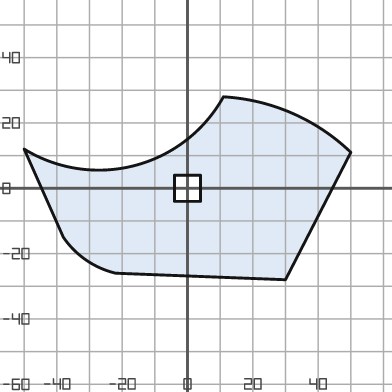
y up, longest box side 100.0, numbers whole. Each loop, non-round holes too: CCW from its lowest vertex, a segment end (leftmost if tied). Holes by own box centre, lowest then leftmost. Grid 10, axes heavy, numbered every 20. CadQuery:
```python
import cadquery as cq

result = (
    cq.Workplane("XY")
    .moveTo(30.0, -28.0)
    .lineTo(50.0, 11.0)
    .threePointArc((32.0, 23.0), (11.0, 28.0))
    .threePointArc((-16.0, 7.0), (-50.0, 12.0))
    .lineTo(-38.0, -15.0)
    .threePointArc((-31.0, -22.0), (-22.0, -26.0))
    .close()
    .moveTo(-4.0, -4.0)
    .lineTo(4.0, -4.0)
    .lineTo(4.0, 4.0)
    .lineTo(-4.0, 4.0)
    .close()
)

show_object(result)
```